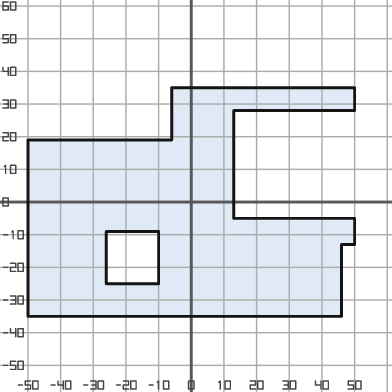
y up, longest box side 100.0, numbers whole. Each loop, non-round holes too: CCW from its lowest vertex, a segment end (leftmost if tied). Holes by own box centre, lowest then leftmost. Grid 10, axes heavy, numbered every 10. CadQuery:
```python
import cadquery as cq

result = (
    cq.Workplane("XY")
    .moveTo(-50.0, -35.0)
    .lineTo(46.0, -35.0)
    .lineTo(46.0, -13.0)
    .lineTo(50.0, -13.0)
    .lineTo(50.0, -5.0)
    .lineTo(13.0, -5.0)
    .lineTo(13.0, 28.0)
    .lineTo(50.0, 28.0)
    .lineTo(50.0, 35.0)
    .lineTo(-6.0, 35.0)
    .lineTo(-6.0, 19.0)
    .lineTo(-50.0, 19.0)
    .close()
    .moveTo(-26.0, -25.0)
    .lineTo(-10.0, -25.0)
    .lineTo(-10.0, -9.0)
    .lineTo(-26.0, -9.0)
    .close()
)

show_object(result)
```